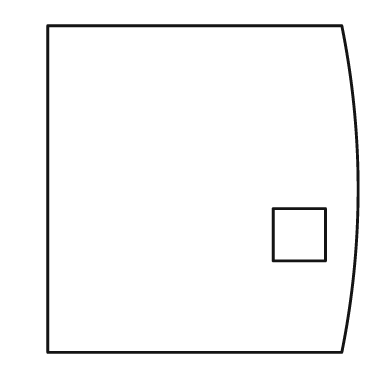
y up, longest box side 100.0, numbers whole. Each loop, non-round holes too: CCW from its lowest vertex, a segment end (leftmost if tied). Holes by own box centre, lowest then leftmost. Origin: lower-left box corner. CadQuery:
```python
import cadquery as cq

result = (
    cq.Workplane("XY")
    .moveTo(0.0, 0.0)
    .lineTo(90.0, 0.0)
    .threePointArc((95.0, 50.0), (90.0, 100.0))
    .lineTo(0.0, 100.0)
    .close()
    .moveTo(69.0, 28.0)
    .lineTo(85.0, 28.0)
    .lineTo(85.0, 44.0)
    .lineTo(69.0, 44.0)
    .close()
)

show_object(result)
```